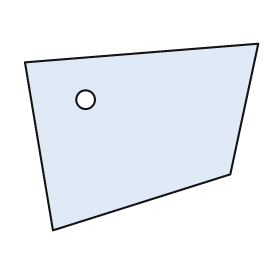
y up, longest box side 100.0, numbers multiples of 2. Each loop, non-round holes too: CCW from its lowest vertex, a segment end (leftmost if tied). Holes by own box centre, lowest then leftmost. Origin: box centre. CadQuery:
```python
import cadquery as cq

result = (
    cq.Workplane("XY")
    .moveTo(-38.0, -40.0)
    .lineTo(38.0, -16.0)
    .lineTo(50.0, 40.0)
    .lineTo(-50.0, 32.0)
    .close()
    .moveTo(-24.0, 16.0)
    .circle(4.0)
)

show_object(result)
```